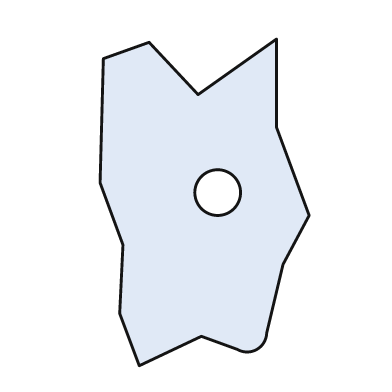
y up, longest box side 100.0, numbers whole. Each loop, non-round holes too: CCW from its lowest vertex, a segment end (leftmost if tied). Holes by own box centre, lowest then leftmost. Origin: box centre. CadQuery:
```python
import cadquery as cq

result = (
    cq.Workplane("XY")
    .moveTo(-20.0, -50.0)
    .lineTo(-1.0, -41.0)
    .lineTo(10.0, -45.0)
    .threePointArc((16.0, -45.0), (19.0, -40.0))
    .lineTo(24.0, -19.0)
    .lineTo(32.0, -4.0)
    .lineTo(22.0, 23.0)
    .lineTo(22.0, 50.0)
    .lineTo(-2.0, 33.0)
    .lineTo(-17.0, 49.0)
    .lineTo(-31.0, 44.0)
    .lineTo(-32.0, 6.0)
    .lineTo(-25.0, -13.0)
    .lineTo(-26.0, -34.0)
    .close()
    .moveTo(4.0, 3.0)
    .circle(7.0)
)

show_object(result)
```